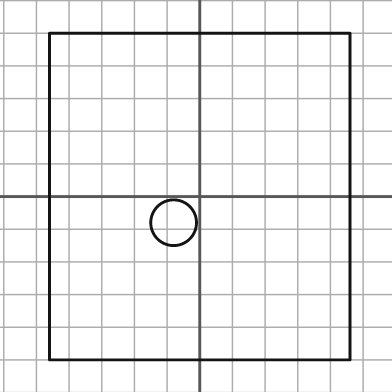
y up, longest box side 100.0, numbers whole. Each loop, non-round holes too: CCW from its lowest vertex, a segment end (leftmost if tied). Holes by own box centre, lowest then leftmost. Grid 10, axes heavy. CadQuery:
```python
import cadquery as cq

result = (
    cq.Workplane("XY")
    .moveTo(-46.0, -50.0)
    .lineTo(46.0, -50.0)
    .lineTo(46.0, 50.0)
    .lineTo(-46.0, 50.0)
    .close()
    .moveTo(-8.0, -8.0)
    .circle(7.0)
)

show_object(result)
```